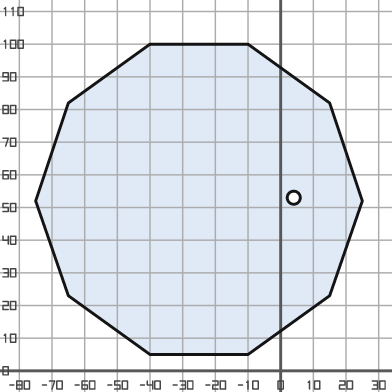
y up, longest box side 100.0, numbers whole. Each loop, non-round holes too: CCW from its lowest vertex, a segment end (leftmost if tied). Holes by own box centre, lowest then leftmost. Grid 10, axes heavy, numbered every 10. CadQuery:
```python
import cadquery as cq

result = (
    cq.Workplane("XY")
    .moveTo(-40.0, 5.0)
    .lineTo(-10.0, 5.0)
    .lineTo(15.0, 23.0)
    .lineTo(25.0, 52.0)
    .lineTo(15.0, 82.0)
    .lineTo(-10.0, 100.0)
    .lineTo(-40.0, 100.0)
    .lineTo(-65.0, 82.0)
    .lineTo(-75.0, 52.0)
    .lineTo(-65.0, 23.0)
    .close()
    .moveTo(4.0, 53.0)
    .circle(2.0)
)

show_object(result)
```